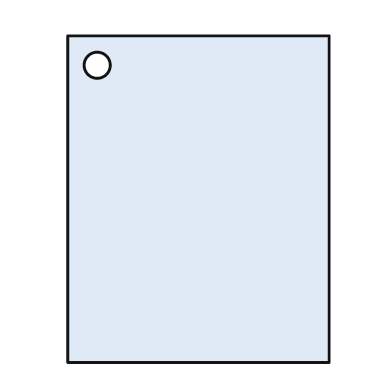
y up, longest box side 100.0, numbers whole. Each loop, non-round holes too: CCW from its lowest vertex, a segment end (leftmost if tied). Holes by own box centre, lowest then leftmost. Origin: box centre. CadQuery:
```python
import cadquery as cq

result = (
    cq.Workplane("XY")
    .moveTo(-40.0, -50.0)
    .lineTo(40.0, -50.0)
    .lineTo(40.0, 50.0)
    .lineTo(-40.0, 50.0)
    .close()
    .moveTo(-31.0, 41.0)
    .circle(4.0)
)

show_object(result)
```